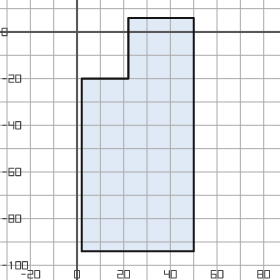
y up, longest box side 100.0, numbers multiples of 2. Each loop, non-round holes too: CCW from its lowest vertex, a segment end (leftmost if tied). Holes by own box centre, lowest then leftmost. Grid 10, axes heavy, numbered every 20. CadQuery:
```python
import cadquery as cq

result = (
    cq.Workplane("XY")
    .moveTo(2.0, -94.0)
    .lineTo(50.0, -94.0)
    .lineTo(50.0, 6.0)
    .lineTo(22.0, 6.0)
    .lineTo(22.0, -20.0)
    .lineTo(2.0, -20.0)
    .close()
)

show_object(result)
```